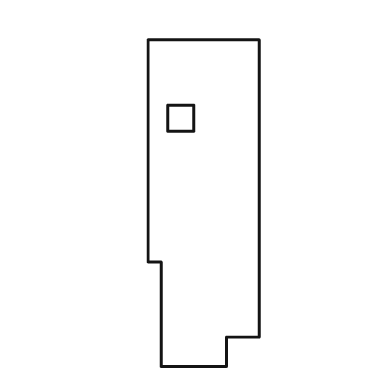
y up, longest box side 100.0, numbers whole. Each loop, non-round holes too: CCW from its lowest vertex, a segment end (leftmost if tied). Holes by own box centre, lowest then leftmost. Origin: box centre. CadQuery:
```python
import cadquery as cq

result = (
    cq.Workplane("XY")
    .moveTo(-13.0, -50.0)
    .lineTo(7.0, -50.0)
    .lineTo(7.0, -41.0)
    .lineTo(17.0, -41.0)
    .lineTo(17.0, 50.0)
    .lineTo(-17.0, 50.0)
    .lineTo(-17.0, -18.0)
    .lineTo(-13.0, -18.0)
    .close()
    .moveTo(-11.0, 22.0)
    .lineTo(-3.0, 22.0)
    .lineTo(-3.0, 30.0)
    .lineTo(-11.0, 30.0)
    .close()
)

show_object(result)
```